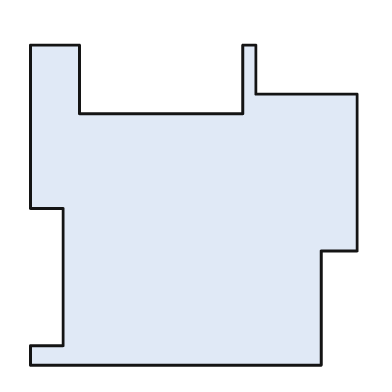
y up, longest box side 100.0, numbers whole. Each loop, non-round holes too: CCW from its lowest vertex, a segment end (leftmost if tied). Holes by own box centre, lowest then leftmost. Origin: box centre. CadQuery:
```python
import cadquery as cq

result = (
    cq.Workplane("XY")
    .moveTo(-50.0, -49.0)
    .lineTo(39.0, -49.0)
    .lineTo(39.0, -14.0)
    .lineTo(50.0, -14.0)
    .lineTo(50.0, 34.0)
    .lineTo(19.0, 34.0)
    .lineTo(19.0, 49.0)
    .lineTo(15.0, 49.0)
    .lineTo(15.0, 28.0)
    .lineTo(-35.0, 28.0)
    .lineTo(-35.0, 49.0)
    .lineTo(-50.0, 49.0)
    .lineTo(-50.0, -1.0)
    .lineTo(-40.0, -1.0)
    .lineTo(-40.0, -43.0)
    .lineTo(-50.0, -43.0)
    .close()
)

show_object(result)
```